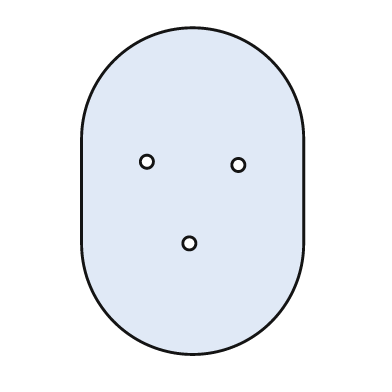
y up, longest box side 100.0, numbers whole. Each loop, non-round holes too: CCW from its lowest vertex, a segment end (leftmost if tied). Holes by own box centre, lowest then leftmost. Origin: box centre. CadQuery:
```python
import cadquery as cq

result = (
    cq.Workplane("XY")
    .moveTo(-34.0, -16.0)
    .threePointArc((0.0, -50.0), (34.0, -16.0))
    .lineTo(34.0, 16.0)
    .threePointArc((0.0, 50.0), (-34.0, 16.0))
    .close()
    .moveTo(-1.0, -16.0)
    .circle(2.0)
    .moveTo(14.0, 8.0)
    .circle(2.0)
    .moveTo(-14.0, 9.0)
    .circle(2.0)
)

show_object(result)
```